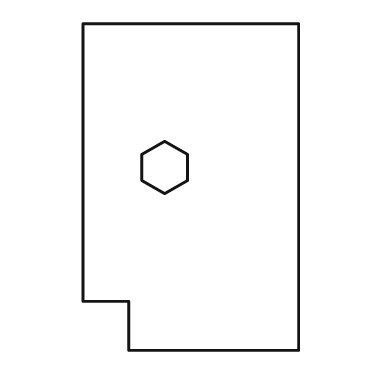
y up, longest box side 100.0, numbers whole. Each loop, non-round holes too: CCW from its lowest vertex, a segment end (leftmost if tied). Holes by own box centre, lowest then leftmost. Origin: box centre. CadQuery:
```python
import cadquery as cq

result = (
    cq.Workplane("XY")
    .moveTo(-19.0, -50.0)
    .lineTo(33.0, -50.0)
    .lineTo(33.0, 50.0)
    .lineTo(-33.0, 50.0)
    .lineTo(-33.0, -35.0)
    .lineTo(-19.0, -35.0)
    .close()
    .moveTo(-8.0, -2.0)
    .lineTo(-1.0, 2.0)
    .lineTo(-1.0, 10.0)
    .lineTo(-8.0, 14.0)
    .lineTo(-15.0, 10.0)
    .lineTo(-15.0, 2.0)
    .close()
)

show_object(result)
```